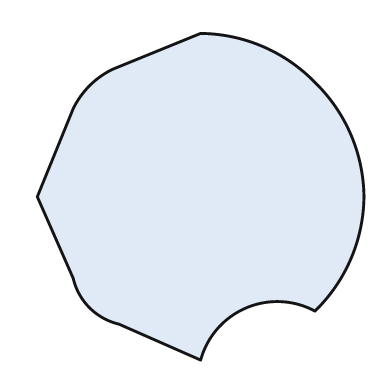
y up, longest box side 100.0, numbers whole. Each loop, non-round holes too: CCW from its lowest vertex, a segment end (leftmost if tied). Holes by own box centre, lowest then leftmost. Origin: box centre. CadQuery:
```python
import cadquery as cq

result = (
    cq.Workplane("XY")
    .moveTo(0.0, -50.0)
    .threePointArc((14.0, -34.0), (35.0, -35.0))
    .threePointArc((46.0, -19.0), (50.0, 0.0))
    .threePointArc((46.0, 19.0), (35.0, 35.0))
    .threePointArc((19.0, 46.0), (0.0, 50.0))
    .lineTo(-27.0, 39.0)
    .threePointArc((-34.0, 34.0), (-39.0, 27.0))
    .lineTo(-50.0, 0.0)
    .lineTo(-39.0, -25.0)
    .threePointArc((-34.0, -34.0), (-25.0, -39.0))
    .close()
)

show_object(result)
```